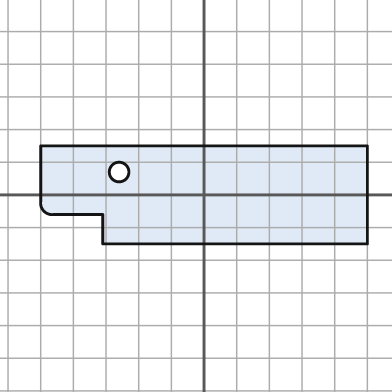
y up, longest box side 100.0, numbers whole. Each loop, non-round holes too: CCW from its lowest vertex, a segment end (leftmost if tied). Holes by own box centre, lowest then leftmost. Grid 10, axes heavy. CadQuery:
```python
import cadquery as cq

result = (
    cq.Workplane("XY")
    .moveTo(-31.0, -15.0)
    .lineTo(50.0, -15.0)
    .lineTo(50.0, 15.0)
    .lineTo(-50.0, 15.0)
    .lineTo(-50.0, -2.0)
    .threePointArc((-49.0, -5.0), (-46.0, -6.0))
    .lineTo(-31.0, -6.0)
    .close()
    .moveTo(-26.0, 7.0)
    .circle(3.0)
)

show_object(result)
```